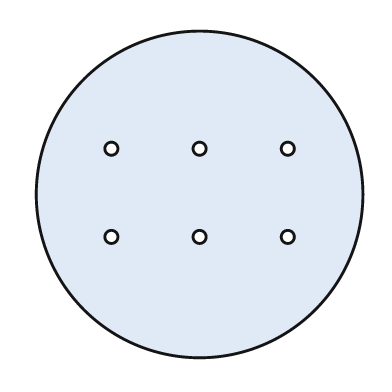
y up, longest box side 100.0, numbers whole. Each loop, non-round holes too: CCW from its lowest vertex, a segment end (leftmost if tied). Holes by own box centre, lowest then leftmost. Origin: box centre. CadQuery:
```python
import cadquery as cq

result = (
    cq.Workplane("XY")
    .moveTo(0.0, 0.0)
    .circle(50.0)
    .moveTo(-27.0, -13.0)
    .circle(2.0)
    .moveTo(0.0, -13.0)
    .circle(2.0)
    .moveTo(27.0, -13.0)
    .circle(2.0)
    .moveTo(-27.0, 14.0)
    .circle(2.0)
    .moveTo(0.0, 14.0)
    .circle(2.0)
    .moveTo(27.0, 14.0)
    .circle(2.0)
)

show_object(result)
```